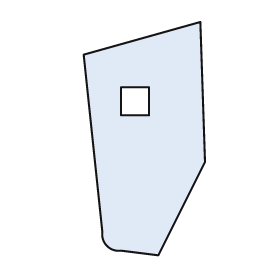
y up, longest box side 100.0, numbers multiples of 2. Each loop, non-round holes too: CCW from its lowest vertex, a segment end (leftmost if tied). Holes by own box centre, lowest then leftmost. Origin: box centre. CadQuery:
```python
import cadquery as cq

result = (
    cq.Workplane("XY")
    .moveTo(6.0, -50.0)
    .lineTo(26.0, -10.0)
    .lineTo(24.0, 50.0)
    .lineTo(-26.0, 36.0)
    .lineTo(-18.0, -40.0)
    .threePointArc((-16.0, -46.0), (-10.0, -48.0))
    .close()
    .moveTo(-10.0, 10.0)
    .lineTo(2.0, 10.0)
    .lineTo(2.0, 22.0)
    .lineTo(-10.0, 22.0)
    .close()
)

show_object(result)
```